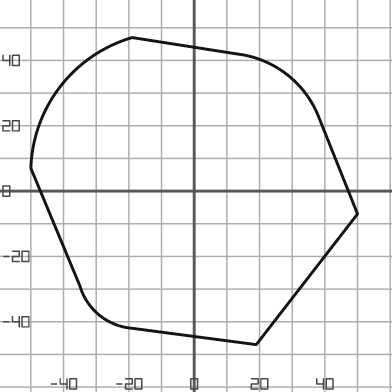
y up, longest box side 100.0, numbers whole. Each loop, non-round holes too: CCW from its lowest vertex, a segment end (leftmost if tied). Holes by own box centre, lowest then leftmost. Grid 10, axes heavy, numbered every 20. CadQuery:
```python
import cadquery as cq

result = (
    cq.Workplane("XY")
    .moveTo(19.0, -47.0)
    .lineTo(50.0, -7.0)
    .lineTo(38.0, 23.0)
    .threePointArc((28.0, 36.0), (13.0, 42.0))
    .lineTo(-19.0, 47.0)
    .threePointArc((-41.0, 32.0), (-50.0, 7.0))
    .lineTo(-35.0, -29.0)
    .threePointArc((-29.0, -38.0), (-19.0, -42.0))
    .close()
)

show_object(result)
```